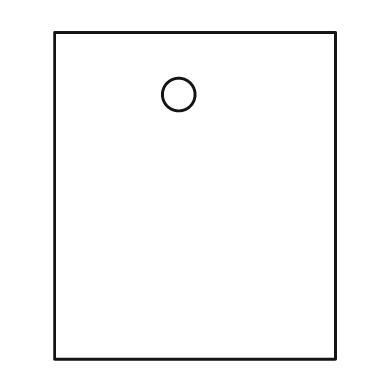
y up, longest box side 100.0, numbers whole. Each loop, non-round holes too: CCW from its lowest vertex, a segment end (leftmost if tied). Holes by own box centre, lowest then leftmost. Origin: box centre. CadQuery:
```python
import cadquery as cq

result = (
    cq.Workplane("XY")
    .moveTo(-43.0, -50.0)
    .lineTo(43.0, -50.0)
    .lineTo(43.0, 50.0)
    .lineTo(-43.0, 50.0)
    .close()
    .moveTo(-5.0, 31.0)
    .circle(5.0)
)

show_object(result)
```